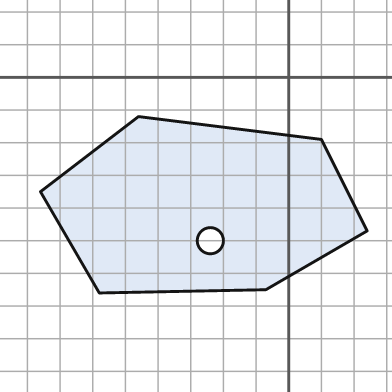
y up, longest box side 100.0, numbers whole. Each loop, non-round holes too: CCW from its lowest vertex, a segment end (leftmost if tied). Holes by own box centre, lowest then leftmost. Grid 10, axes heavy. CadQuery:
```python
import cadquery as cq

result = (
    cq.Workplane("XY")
    .moveTo(-58.0, -66.0)
    .lineTo(-7.0, -65.0)
    .lineTo(24.0, -47.0)
    .lineTo(10.0, -19.0)
    .lineTo(-46.0, -12.0)
    .lineTo(-76.0, -35.0)
    .close()
    .moveTo(-24.0, -50.0)
    .circle(4.0)
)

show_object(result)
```